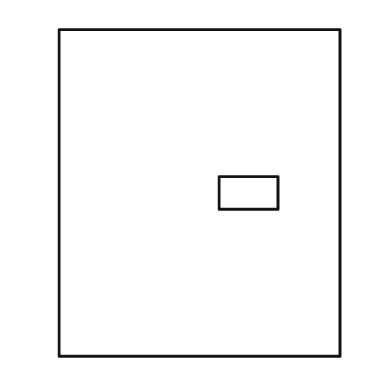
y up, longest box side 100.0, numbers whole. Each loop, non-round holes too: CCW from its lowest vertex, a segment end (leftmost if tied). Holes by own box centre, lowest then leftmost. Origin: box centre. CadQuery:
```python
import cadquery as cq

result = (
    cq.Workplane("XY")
    .moveTo(-43.0, -50.0)
    .lineTo(43.0, -50.0)
    .lineTo(43.0, 50.0)
    .lineTo(-43.0, 50.0)
    .close()
    .moveTo(6.0, -5.0)
    .lineTo(24.0, -5.0)
    .lineTo(24.0, 5.0)
    .lineTo(6.0, 5.0)
    .close()
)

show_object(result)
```